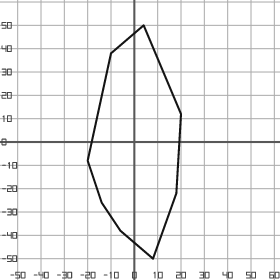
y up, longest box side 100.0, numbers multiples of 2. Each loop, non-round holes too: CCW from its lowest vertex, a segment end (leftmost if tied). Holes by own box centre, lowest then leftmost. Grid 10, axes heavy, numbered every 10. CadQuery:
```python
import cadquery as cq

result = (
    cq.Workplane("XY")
    .moveTo(8.0, -50.0)
    .lineTo(18.0, -22.0)
    .lineTo(20.0, 12.0)
    .lineTo(4.0, 50.0)
    .lineTo(-10.0, 38.0)
    .lineTo(-20.0, -8.0)
    .lineTo(-14.0, -26.0)
    .lineTo(-6.0, -38.0)
    .close()
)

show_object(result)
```